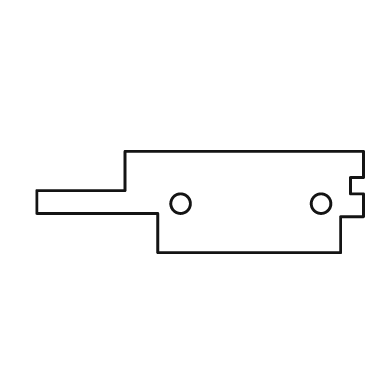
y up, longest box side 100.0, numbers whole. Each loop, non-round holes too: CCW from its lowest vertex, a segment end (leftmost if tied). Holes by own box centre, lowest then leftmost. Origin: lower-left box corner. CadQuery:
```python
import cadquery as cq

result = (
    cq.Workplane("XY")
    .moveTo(37.0, 0.0)
    .lineTo(93.0, 0.0)
    .lineTo(93.0, 11.0)
    .lineTo(100.0, 11.0)
    .lineTo(100.0, 18.0)
    .lineTo(96.0, 18.0)
    .lineTo(96.0, 23.0)
    .lineTo(100.0, 23.0)
    .lineTo(100.0, 31.0)
    .lineTo(27.0, 31.0)
    .lineTo(27.0, 19.0)
    .lineTo(0.0, 19.0)
    .lineTo(0.0, 12.0)
    .lineTo(37.0, 12.0)
    .close()
    .moveTo(44.0, 15.0)
    .circle(3.0)
    .moveTo(87.0, 15.0)
    .circle(3.0)
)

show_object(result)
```